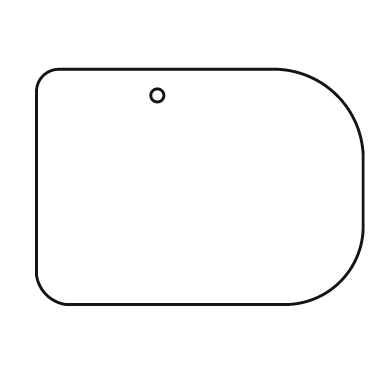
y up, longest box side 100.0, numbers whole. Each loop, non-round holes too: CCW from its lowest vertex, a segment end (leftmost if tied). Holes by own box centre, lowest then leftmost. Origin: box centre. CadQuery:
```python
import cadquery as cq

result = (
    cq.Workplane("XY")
    .moveTo(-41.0, -36.0)
    .lineTo(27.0, -36.0)
    .threePointArc((43.0, -29.0), (50.0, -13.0))
    .lineTo(50.0, 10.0)
    .threePointArc((42.0, 28.0), (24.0, 36.0))
    .lineTo(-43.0, 36.0)
    .threePointArc((-48.0, 34.0), (-50.0, 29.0))
    .lineTo(-50.0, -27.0)
    .threePointArc((-47.0, -33.0), (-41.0, -36.0))
    .close()
    .moveTo(-13.0, 28.0)
    .circle(2.0)
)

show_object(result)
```